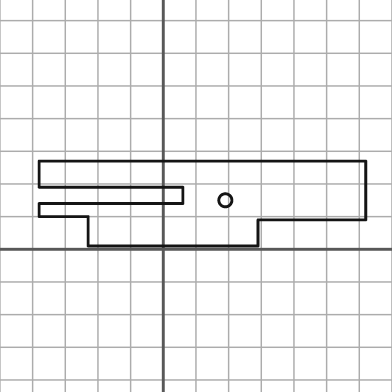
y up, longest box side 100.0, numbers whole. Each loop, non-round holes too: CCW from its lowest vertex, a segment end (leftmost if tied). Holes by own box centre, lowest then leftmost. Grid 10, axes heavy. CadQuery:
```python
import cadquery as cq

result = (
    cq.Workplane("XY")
    .moveTo(-23.0, 1.0)
    .lineTo(29.0, 1.0)
    .lineTo(29.0, 9.0)
    .lineTo(62.0, 9.0)
    .lineTo(62.0, 27.0)
    .lineTo(-38.0, 27.0)
    .lineTo(-38.0, 19.0)
    .lineTo(6.0, 19.0)
    .lineTo(6.0, 14.0)
    .lineTo(-38.0, 14.0)
    .lineTo(-38.0, 10.0)
    .lineTo(-23.0, 10.0)
    .close()
    .moveTo(19.0, 15.0)
    .circle(2.0)
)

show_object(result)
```